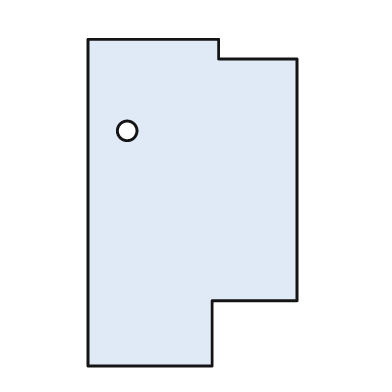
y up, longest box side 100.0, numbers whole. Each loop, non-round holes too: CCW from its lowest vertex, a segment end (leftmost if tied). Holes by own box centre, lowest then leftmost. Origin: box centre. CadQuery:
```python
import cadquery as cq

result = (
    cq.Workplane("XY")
    .moveTo(-32.0, -50.0)
    .lineTo(6.0, -50.0)
    .lineTo(6.0, -30.0)
    .lineTo(32.0, -30.0)
    .lineTo(32.0, 44.0)
    .lineTo(8.0, 44.0)
    .lineTo(8.0, 50.0)
    .lineTo(-32.0, 50.0)
    .close()
    .moveTo(-20.0, 22.0)
    .circle(3.0)
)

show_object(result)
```